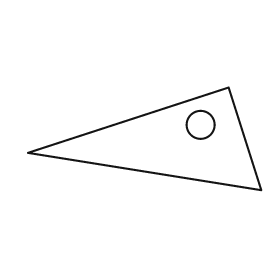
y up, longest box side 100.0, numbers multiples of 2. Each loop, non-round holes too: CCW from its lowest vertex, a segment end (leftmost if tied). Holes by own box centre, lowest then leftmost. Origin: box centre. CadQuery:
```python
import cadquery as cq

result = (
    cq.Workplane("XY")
    .moveTo(50.0, -22.0)
    .lineTo(36.0, 22.0)
    .lineTo(-50.0, -6.0)
    .close()
    .moveTo(24.0, 6.0)
    .circle(6.0)
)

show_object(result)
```